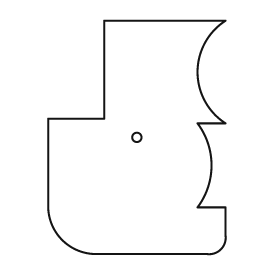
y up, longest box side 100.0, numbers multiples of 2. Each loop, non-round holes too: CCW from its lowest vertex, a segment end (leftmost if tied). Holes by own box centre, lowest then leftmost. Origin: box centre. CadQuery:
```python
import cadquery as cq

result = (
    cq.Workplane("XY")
    .moveTo(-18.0, -50.0)
    .lineTo(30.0, -50.0)
    .threePointArc((36.0, -48.0), (38.0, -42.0))
    .lineTo(38.0, -30.0)
    .lineTo(26.0, -30.0)
    .threePointArc((32.0, -12.0), (26.0, 6.0))
    .lineTo(38.0, 6.0)
    .threePointArc((26.0, 28.0), (38.0, 50.0))
    .lineTo(-14.0, 50.0)
    .lineTo(-14.0, 8.0)
    .lineTo(-38.0, 8.0)
    .lineTo(-38.0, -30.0)
    .threePointArc((-32.0, -44.0), (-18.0, -50.0))
    .close()
    .moveTo(0.0, 0.0)
    .circle(2.0)
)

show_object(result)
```